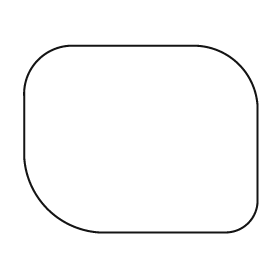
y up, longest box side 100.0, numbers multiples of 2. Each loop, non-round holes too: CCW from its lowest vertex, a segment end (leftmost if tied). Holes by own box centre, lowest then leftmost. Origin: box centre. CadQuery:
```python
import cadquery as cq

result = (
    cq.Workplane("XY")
    .moveTo(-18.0, -40.0)
    .lineTo(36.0, -40.0)
    .threePointArc((46.0, -36.0), (50.0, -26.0))
    .lineTo(50.0, 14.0)
    .threePointArc((42.0, 32.0), (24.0, 40.0))
    .lineTo(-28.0, 40.0)
    .threePointArc((-44.0, 34.0), (-50.0, 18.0))
    .lineTo(-50.0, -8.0)
    .threePointArc((-40.0, -30.0), (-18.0, -40.0))
    .close()
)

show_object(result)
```